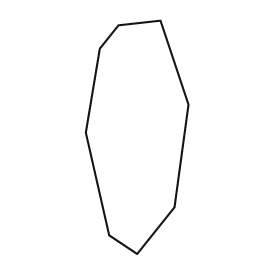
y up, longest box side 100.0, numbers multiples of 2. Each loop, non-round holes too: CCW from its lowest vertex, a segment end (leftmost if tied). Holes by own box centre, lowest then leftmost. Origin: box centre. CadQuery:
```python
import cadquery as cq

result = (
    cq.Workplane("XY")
    .moveTo(0.0, -50.0)
    .lineTo(16.0, -30.0)
    .lineTo(22.0, 14.0)
    .lineTo(10.0, 50.0)
    .lineTo(-8.0, 48.0)
    .lineTo(-16.0, 38.0)
    .lineTo(-22.0, 2.0)
    .lineTo(-12.0, -42.0)
    .close()
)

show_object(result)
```